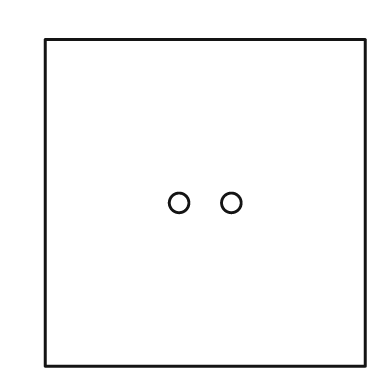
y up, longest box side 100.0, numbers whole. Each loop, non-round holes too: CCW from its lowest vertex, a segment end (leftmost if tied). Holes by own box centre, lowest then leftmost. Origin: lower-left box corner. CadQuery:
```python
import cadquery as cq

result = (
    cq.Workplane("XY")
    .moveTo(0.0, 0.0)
    .lineTo(98.0, 0.0)
    .lineTo(98.0, 100.0)
    .lineTo(0.0, 100.0)
    .close()
    .moveTo(41.0, 50.0)
    .circle(3.0)
    .moveTo(57.0, 50.0)
    .circle(3.0)
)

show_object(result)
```